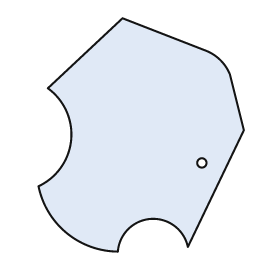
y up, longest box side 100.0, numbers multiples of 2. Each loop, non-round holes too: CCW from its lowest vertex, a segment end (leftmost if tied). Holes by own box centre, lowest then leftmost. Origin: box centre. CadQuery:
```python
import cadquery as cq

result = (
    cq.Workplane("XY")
    .moveTo(-10.0, -50.0)
    .threePointArc((4.0, -36.0), (20.0, -48.0))
    .lineTo(44.0, 2.0)
    .lineTo(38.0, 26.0)
    .threePointArc((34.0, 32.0), (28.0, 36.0))
    .lineTo(-8.0, 50.0)
    .lineTo(-40.0, 20.0)
    .threePointArc((-30.0, -2.0), (-44.0, -22.0))
    .threePointArc((-32.0, -42.0), (-10.0, -50.0))
    .close()
    .moveTo(26.0, -12.0)
    .circle(2.0)
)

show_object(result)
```